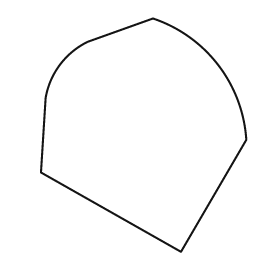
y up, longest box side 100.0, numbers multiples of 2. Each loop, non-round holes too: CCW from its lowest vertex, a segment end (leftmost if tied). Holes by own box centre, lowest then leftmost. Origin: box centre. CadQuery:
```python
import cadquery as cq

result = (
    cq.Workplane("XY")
    .moveTo(16.0, -50.0)
    .lineTo(44.0, -2.0)
    .threePointArc((32.0, 30.0), (4.0, 50.0))
    .lineTo(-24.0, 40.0)
    .threePointArc((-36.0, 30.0), (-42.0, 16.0))
    .lineTo(-44.0, -16.0)
    .close()
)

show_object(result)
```